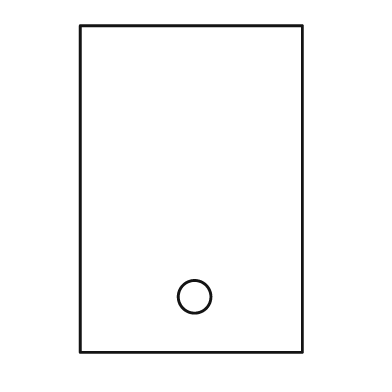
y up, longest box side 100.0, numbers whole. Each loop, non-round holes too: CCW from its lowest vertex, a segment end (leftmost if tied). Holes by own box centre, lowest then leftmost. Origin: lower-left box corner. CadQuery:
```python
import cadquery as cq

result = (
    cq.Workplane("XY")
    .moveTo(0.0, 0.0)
    .lineTo(68.0, 0.0)
    .lineTo(68.0, 100.0)
    .lineTo(0.0, 100.0)
    .close()
    .moveTo(35.0, 17.0)
    .circle(5.0)
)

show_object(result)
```